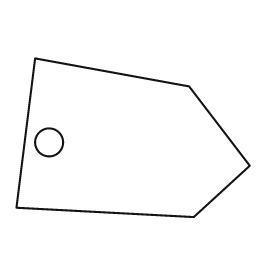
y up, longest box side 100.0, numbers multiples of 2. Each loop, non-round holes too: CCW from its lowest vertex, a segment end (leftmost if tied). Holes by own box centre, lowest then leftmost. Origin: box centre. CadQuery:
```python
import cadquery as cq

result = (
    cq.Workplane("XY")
    .moveTo(26.0, -34.0)
    .lineTo(50.0, -12.0)
    .lineTo(24.0, 22.0)
    .lineTo(-42.0, 34.0)
    .lineTo(-50.0, -30.0)
    .close()
    .moveTo(-36.0, -2.0)
    .circle(6.0)
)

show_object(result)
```